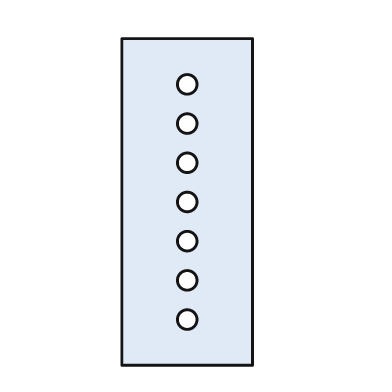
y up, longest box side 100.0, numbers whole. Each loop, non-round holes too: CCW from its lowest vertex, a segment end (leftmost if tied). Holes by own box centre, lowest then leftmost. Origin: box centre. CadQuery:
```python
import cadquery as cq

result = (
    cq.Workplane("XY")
    .moveTo(-20.0, -50.0)
    .lineTo(20.0, -50.0)
    .lineTo(20.0, 50.0)
    .lineTo(-20.0, 50.0)
    .close()
    .moveTo(0.0, -36.0)
    .circle(3.0)
    .moveTo(0.0, -24.0)
    .circle(3.0)
    .moveTo(0.0, -12.0)
    .circle(3.0)
    .moveTo(0.0, 0.0)
    .circle(3.0)
    .moveTo(0.0, 12.0)
    .circle(3.0)
    .moveTo(0.0, 24.0)
    .circle(3.0)
    .moveTo(0.0, 36.0)
    .circle(3.0)
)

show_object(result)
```